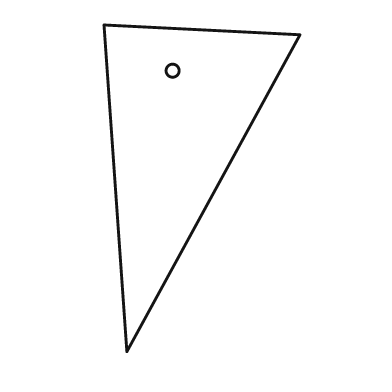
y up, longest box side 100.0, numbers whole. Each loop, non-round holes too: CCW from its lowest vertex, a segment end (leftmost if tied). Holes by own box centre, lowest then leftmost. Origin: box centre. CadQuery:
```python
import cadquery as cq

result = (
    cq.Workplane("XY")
    .moveTo(-23.0, -50.0)
    .lineTo(30.0, 47.0)
    .lineTo(-30.0, 50.0)
    .close()
    .moveTo(-9.0, 36.0)
    .circle(2.0)
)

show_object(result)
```